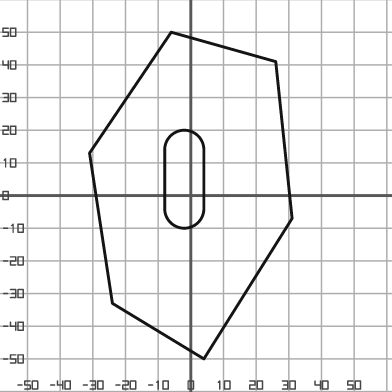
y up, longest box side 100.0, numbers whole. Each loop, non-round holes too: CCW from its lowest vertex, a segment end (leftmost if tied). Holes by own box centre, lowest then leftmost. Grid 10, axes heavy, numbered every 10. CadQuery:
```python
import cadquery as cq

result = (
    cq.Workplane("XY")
    .moveTo(4.0, -50.0)
    .lineTo(31.0, -7.0)
    .lineTo(26.0, 41.0)
    .lineTo(-6.0, 50.0)
    .lineTo(-31.0, 13.0)
    .lineTo(-24.0, -33.0)
    .close()
    .moveTo(-8.0, -4.0)
    .threePointArc((-2.0, -10.0), (4.0, -4.0))
    .lineTo(4.0, 14.0)
    .threePointArc((-2.0, 20.0), (-8.0, 14.0))
    .close()
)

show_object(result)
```